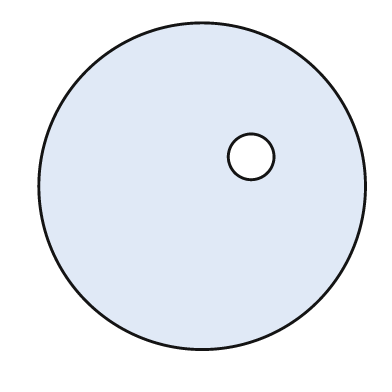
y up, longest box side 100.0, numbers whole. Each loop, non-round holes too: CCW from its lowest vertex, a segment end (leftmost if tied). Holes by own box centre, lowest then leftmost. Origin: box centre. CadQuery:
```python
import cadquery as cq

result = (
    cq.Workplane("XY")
    .moveTo(0.0, 0.0)
    .circle(50.0)
    .moveTo(15.0, 9.0)
    .circle(7.0)
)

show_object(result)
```